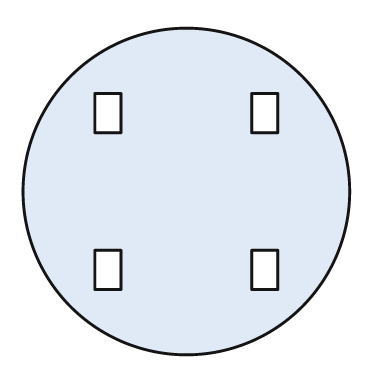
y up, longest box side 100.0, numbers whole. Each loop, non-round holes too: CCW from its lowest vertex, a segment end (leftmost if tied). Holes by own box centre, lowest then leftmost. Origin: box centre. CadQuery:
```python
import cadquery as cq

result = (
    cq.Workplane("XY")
    .moveTo(0.0, 0.0)
    .circle(50.0)
    .moveTo(-28.0, -30.0)
    .lineTo(-20.0, -30.0)
    .lineTo(-20.0, -18.0)
    .lineTo(-28.0, -18.0)
    .close()
    .moveTo(20.0, -30.0)
    .lineTo(28.0, -30.0)
    .lineTo(28.0, -18.0)
    .lineTo(20.0, -18.0)
    .close()
    .moveTo(-28.0, 18.0)
    .lineTo(-20.0, 18.0)
    .lineTo(-20.0, 30.0)
    .lineTo(-28.0, 30.0)
    .close()
    .moveTo(20.0, 18.0)
    .lineTo(28.0, 18.0)
    .lineTo(28.0, 30.0)
    .lineTo(20.0, 30.0)
    .close()
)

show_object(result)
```